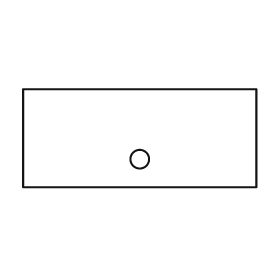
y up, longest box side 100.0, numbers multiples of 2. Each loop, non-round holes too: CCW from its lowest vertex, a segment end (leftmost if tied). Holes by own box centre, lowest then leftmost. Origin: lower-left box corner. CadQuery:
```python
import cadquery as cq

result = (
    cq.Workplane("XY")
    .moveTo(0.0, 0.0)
    .lineTo(100.0, 0.0)
    .lineTo(100.0, 42.0)
    .lineTo(0.0, 42.0)
    .close()
    .moveTo(50.0, 12.0)
    .circle(4.0)
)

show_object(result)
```